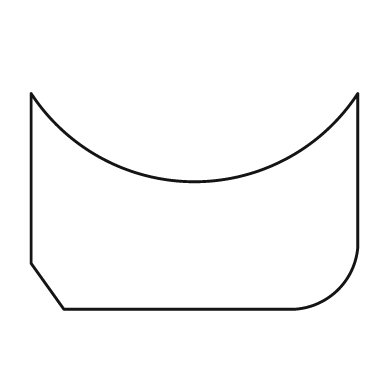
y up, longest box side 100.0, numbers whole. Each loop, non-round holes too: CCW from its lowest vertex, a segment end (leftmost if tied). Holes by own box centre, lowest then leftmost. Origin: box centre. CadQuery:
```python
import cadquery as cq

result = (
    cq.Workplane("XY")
    .moveTo(-40.0, -33.0)
    .lineTo(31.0, -33.0)
    .threePointArc((44.0, -27.0), (50.0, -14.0))
    .lineTo(50.0, 33.0)
    .threePointArc((0.0, 6.0), (-50.0, 33.0))
    .lineTo(-50.0, -19.0)
    .close()
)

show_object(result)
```